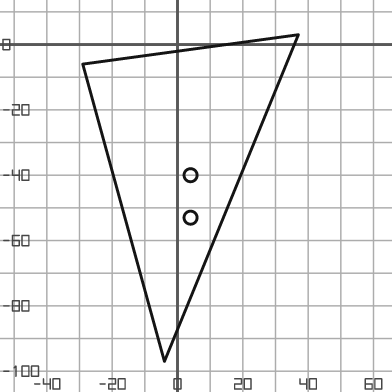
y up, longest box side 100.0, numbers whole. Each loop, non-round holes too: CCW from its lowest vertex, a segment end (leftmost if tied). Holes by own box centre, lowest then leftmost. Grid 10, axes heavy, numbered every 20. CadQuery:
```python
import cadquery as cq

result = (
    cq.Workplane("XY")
    .moveTo(-4.0, -97.0)
    .lineTo(37.0, 3.0)
    .lineTo(-29.0, -6.0)
    .close()
    .moveTo(4.0, -53.0)
    .circle(2.0)
    .moveTo(4.0, -40.0)
    .circle(2.0)
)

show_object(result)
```